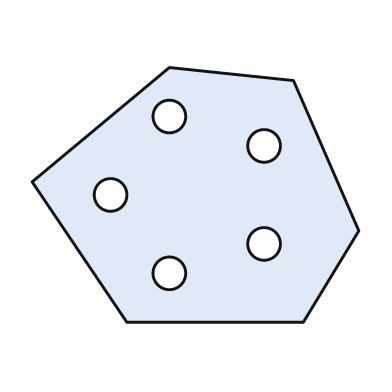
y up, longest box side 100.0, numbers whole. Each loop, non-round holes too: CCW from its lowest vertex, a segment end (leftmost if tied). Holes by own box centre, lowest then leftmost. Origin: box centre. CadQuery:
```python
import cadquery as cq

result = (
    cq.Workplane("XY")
    .moveTo(-21.0, -39.0)
    .lineTo(33.0, -39.0)
    .lineTo(50.0, -11.0)
    .lineTo(30.0, 35.0)
    .lineTo(-8.0, 39.0)
    .lineTo(-50.0, 4.0)
    .close()
    .moveTo(-8.0, -24.0)
    .circle(5.0)
    .moveTo(21.0, -15.0)
    .circle(5.0)
    .moveTo(-26.0, 0.0)
    .circle(5.0)
    .moveTo(21.0, 15.0)
    .circle(5.0)
    .moveTo(-8.0, 24.0)
    .circle(5.0)
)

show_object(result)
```